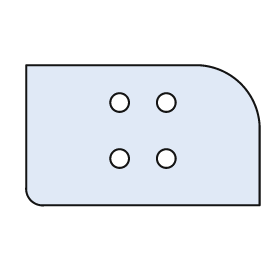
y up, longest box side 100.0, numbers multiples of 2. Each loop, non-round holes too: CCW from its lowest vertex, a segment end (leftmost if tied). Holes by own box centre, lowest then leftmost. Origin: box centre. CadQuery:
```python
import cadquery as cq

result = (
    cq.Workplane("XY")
    .moveTo(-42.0, -30.0)
    .lineTo(50.0, -30.0)
    .lineTo(50.0, 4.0)
    .threePointArc((42.0, 22.0), (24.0, 30.0))
    .lineTo(-50.0, 30.0)
    .lineTo(-50.0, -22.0)
    .threePointArc((-48.0, -28.0), (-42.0, -30.0))
    .close()
    .moveTo(-10.0, -10.0)
    .circle(4.0)
    .moveTo(10.0, -10.0)
    .circle(4.0)
    .moveTo(-10.0, 14.0)
    .circle(4.0)
    .moveTo(10.0, 14.0)
    .circle(4.0)
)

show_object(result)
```